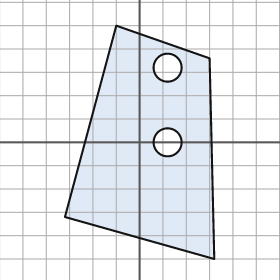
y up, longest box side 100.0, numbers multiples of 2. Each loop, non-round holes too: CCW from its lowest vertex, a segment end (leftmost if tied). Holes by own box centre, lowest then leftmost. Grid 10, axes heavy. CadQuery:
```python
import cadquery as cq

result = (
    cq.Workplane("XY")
    .moveTo(32.0, -50.0)
    .lineTo(30.0, 36.0)
    .lineTo(-10.0, 50.0)
    .lineTo(-32.0, -32.0)
    .close()
    .moveTo(12.0, 0.0)
    .circle(6.0)
    .moveTo(12.0, 32.0)
    .circle(6.0)
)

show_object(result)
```